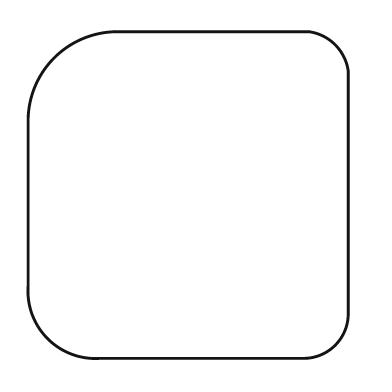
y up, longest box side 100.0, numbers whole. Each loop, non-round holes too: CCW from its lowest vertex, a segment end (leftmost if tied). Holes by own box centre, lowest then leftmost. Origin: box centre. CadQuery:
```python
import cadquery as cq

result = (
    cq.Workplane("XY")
    .moveTo(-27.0, -50.0)
    .lineTo(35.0, -50.0)
    .threePointArc((45.0, -46.0), (49.0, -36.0))
    .lineTo(49.0, 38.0)
    .threePointArc((45.0, 46.0), (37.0, 50.0))
    .lineTo(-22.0, 50.0)
    .threePointArc((-41.0, 42.0), (-49.0, 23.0))
    .lineTo(-49.0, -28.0)
    .threePointArc((-43.0, -44.0), (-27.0, -50.0))
    .close()
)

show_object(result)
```